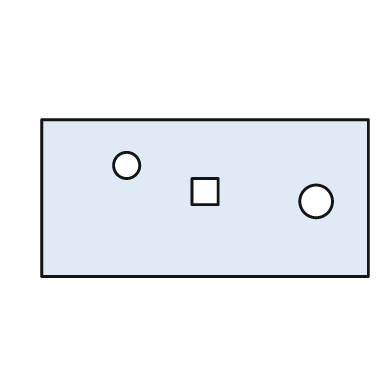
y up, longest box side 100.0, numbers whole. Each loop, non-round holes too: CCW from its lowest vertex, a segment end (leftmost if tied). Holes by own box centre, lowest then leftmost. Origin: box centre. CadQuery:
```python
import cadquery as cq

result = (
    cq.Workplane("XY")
    .moveTo(-50.0, -24.0)
    .lineTo(50.0, -24.0)
    .lineTo(50.0, 24.0)
    .lineTo(-50.0, 24.0)
    .close()
    .moveTo(34.0, -1.0)
    .circle(5.0)
    .moveTo(-4.0, -2.0)
    .lineTo(4.0, -2.0)
    .lineTo(4.0, 6.0)
    .lineTo(-4.0, 6.0)
    .close()
    .moveTo(-24.0, 10.0)
    .circle(4.0)
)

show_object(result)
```